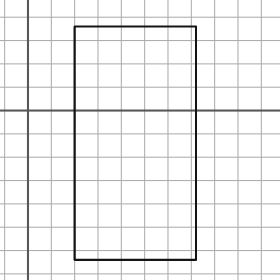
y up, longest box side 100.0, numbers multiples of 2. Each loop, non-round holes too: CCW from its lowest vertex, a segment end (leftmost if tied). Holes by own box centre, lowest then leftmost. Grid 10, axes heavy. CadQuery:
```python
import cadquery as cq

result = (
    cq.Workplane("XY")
    .moveTo(20.0, -64.0)
    .lineTo(72.0, -64.0)
    .lineTo(72.0, 36.0)
    .lineTo(20.0, 36.0)
    .close()
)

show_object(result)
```